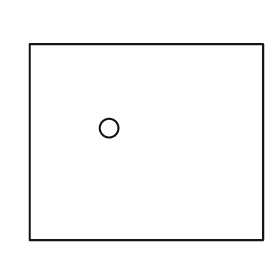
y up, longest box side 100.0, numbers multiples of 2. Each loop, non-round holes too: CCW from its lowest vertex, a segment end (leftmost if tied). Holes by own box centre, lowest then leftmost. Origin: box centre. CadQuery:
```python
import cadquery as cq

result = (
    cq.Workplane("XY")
    .moveTo(-50.0, -42.0)
    .lineTo(50.0, -42.0)
    .lineTo(50.0, 42.0)
    .lineTo(-50.0, 42.0)
    .close()
    .moveTo(-16.0, 6.0)
    .circle(4.0)
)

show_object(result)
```